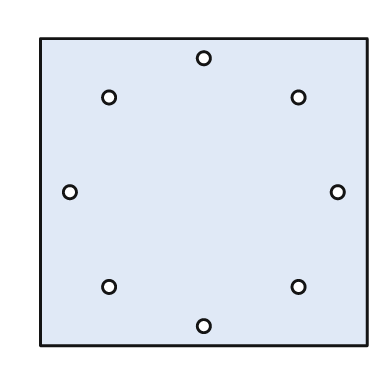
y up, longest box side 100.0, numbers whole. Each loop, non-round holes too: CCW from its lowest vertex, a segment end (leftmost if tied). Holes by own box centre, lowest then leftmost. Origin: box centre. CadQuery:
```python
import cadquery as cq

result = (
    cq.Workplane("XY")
    .moveTo(-50.0, -47.0)
    .lineTo(50.0, -47.0)
    .lineTo(50.0, 47.0)
    .lineTo(-50.0, 47.0)
    .close()
    .moveTo(0.0, -41.0)
    .circle(2.0)
    .moveTo(-29.0, -29.0)
    .circle(2.0)
    .moveTo(29.0, -29.0)
    .circle(2.0)
    .moveTo(-41.0, 0.0)
    .circle(2.0)
    .moveTo(41.0, 0.0)
    .circle(2.0)
    .moveTo(-29.0, 29.0)
    .circle(2.0)
    .moveTo(29.0, 29.0)
    .circle(2.0)
    .moveTo(0.0, 41.0)
    .circle(2.0)
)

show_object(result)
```